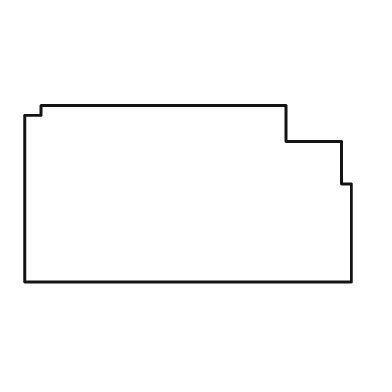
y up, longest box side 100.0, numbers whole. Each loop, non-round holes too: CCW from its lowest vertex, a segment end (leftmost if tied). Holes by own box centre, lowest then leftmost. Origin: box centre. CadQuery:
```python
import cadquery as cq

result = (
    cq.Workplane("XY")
    .moveTo(-50.0, -27.0)
    .lineTo(50.0, -27.0)
    .lineTo(50.0, 3.0)
    .lineTo(47.0, 3.0)
    .lineTo(47.0, 16.0)
    .lineTo(30.0, 16.0)
    .lineTo(30.0, 27.0)
    .lineTo(-45.0, 27.0)
    .lineTo(-45.0, 24.0)
    .lineTo(-50.0, 24.0)
    .close()
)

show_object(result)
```